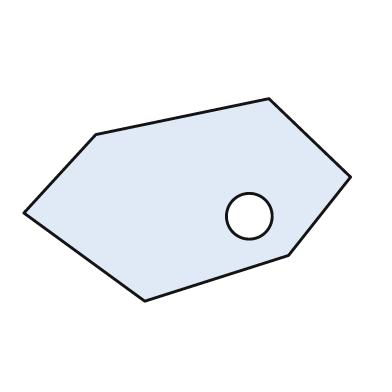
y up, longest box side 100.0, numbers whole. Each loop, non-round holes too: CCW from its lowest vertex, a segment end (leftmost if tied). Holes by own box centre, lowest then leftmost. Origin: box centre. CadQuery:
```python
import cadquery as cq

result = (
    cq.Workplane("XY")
    .moveTo(-13.0, -31.0)
    .lineTo(31.0, -17.0)
    .lineTo(50.0, 7.0)
    .lineTo(25.0, 31.0)
    .lineTo(-28.0, 20.0)
    .lineTo(-50.0, -4.0)
    .close()
    .moveTo(19.0, -5.0)
    .circle(7.0)
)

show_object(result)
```